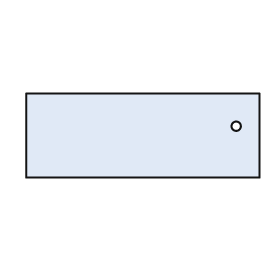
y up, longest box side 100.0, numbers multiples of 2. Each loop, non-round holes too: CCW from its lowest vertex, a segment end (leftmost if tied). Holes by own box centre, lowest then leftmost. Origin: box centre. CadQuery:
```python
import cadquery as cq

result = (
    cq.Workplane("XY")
    .moveTo(-50.0, -18.0)
    .lineTo(50.0, -18.0)
    .lineTo(50.0, 18.0)
    .lineTo(-50.0, 18.0)
    .close()
    .moveTo(40.0, 4.0)
    .circle(2.0)
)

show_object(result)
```